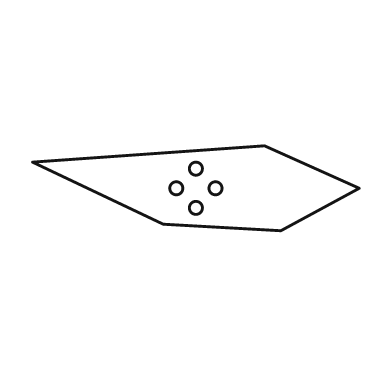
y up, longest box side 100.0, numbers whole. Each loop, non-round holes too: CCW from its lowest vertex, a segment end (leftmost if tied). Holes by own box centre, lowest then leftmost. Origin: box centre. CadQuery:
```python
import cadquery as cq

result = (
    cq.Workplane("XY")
    .moveTo(26.0, -13.0)
    .lineTo(50.0, 0.0)
    .lineTo(21.0, 13.0)
    .lineTo(-50.0, 8.0)
    .lineTo(-10.0, -11.0)
    .close()
    .moveTo(0.0, -6.0)
    .circle(2.0)
    .moveTo(-6.0, 0.0)
    .circle(2.0)
    .moveTo(6.0, 0.0)
    .circle(2.0)
    .moveTo(0.0, 6.0)
    .circle(2.0)
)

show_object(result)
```